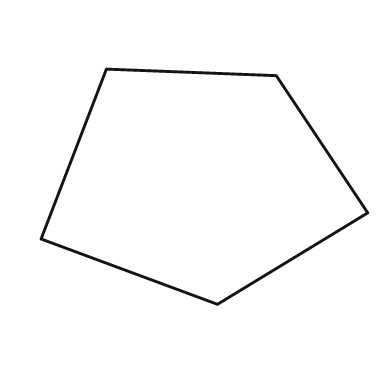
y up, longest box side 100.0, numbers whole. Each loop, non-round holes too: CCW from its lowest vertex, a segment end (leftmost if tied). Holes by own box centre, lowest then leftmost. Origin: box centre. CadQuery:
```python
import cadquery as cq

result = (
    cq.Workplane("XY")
    .moveTo(4.0, -36.0)
    .lineTo(50.0, -8.0)
    .lineTo(22.0, 34.0)
    .lineTo(-30.0, 36.0)
    .lineTo(-50.0, -16.0)
    .close()
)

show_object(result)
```